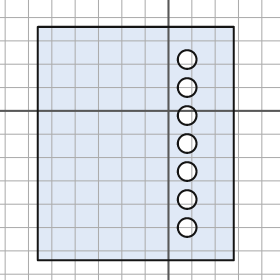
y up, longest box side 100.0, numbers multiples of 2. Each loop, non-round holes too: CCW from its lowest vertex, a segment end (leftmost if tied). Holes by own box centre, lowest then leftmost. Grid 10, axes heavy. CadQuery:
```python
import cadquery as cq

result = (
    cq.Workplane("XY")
    .moveTo(-56.0, -64.0)
    .lineTo(28.0, -64.0)
    .lineTo(28.0, 36.0)
    .lineTo(-56.0, 36.0)
    .close()
    .moveTo(8.0, -50.0)
    .circle(4.0)
    .moveTo(8.0, -38.0)
    .circle(4.0)
    .moveTo(8.0, -26.0)
    .circle(4.0)
    .moveTo(8.0, -14.0)
    .circle(4.0)
    .moveTo(8.0, -2.0)
    .circle(4.0)
    .moveTo(8.0, 10.0)
    .circle(4.0)
    .moveTo(8.0, 22.0)
    .circle(4.0)
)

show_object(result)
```